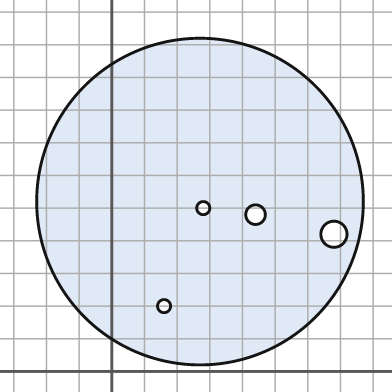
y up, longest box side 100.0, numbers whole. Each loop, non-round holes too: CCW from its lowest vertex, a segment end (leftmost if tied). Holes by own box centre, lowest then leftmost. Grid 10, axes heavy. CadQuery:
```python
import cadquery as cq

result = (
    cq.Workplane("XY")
    .moveTo(27.0, 52.0)
    .circle(50.0)
    .moveTo(16.0, 20.0)
    .circle(2.0)
    .moveTo(68.0, 42.0)
    .circle(4.0)
    .moveTo(44.0, 48.0)
    .circle(3.0)
    .moveTo(28.0, 50.0)
    .circle(2.0)
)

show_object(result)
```